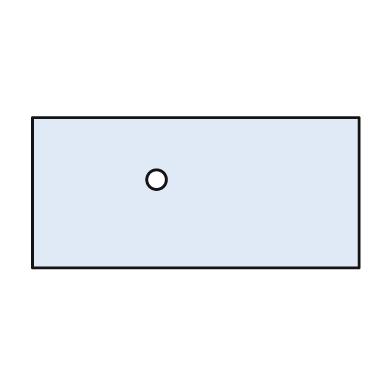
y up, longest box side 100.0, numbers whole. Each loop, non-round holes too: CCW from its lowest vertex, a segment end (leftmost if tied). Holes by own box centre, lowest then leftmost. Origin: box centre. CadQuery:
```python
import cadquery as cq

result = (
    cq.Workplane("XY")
    .moveTo(-50.0, -23.0)
    .lineTo(50.0, -23.0)
    .lineTo(50.0, 23.0)
    .lineTo(-50.0, 23.0)
    .close()
    .moveTo(-12.0, 4.0)
    .circle(3.0)
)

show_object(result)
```